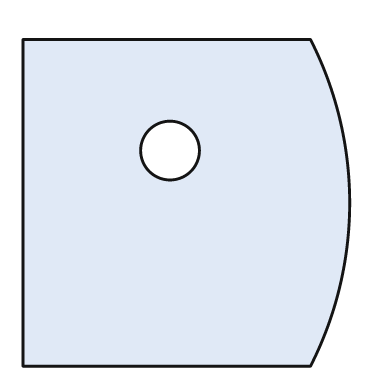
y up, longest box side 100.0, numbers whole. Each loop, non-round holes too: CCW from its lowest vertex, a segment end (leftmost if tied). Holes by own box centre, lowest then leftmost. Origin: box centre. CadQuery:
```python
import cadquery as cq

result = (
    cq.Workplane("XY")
    .moveTo(-50.0, -50.0)
    .lineTo(38.0, -50.0)
    .threePointArc((50.0, 0.0), (38.0, 50.0))
    .lineTo(-50.0, 50.0)
    .close()
    .moveTo(-5.0, 16.0)
    .circle(9.0)
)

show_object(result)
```